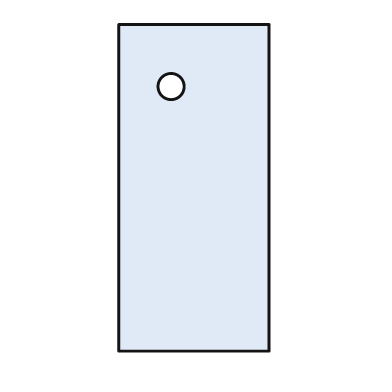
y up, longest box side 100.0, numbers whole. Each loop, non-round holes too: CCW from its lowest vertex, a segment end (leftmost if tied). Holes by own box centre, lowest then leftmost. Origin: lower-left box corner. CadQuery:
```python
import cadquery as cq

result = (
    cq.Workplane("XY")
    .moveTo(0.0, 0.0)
    .lineTo(46.0, 0.0)
    .lineTo(46.0, 100.0)
    .lineTo(0.0, 100.0)
    .close()
    .moveTo(16.0, 81.0)
    .circle(4.0)
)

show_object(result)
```